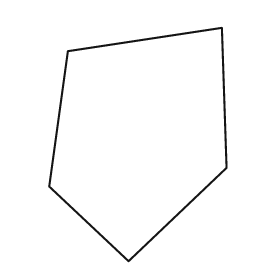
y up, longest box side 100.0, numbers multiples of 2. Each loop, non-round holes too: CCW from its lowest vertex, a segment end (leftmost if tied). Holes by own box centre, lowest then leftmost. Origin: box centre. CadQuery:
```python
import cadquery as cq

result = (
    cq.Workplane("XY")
    .moveTo(-4.0, -50.0)
    .lineTo(38.0, -10.0)
    .lineTo(36.0, 50.0)
    .lineTo(-30.0, 40.0)
    .lineTo(-38.0, -18.0)
    .close()
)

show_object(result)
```